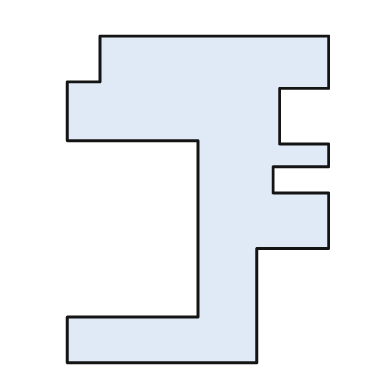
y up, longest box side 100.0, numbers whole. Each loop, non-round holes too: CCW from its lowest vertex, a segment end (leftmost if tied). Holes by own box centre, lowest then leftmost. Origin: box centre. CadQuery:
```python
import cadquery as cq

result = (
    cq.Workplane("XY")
    .moveTo(-40.0, -50.0)
    .lineTo(18.0, -50.0)
    .lineTo(18.0, -15.0)
    .lineTo(40.0, -15.0)
    .lineTo(40.0, 2.0)
    .lineTo(23.0, 2.0)
    .lineTo(23.0, 10.0)
    .lineTo(40.0, 10.0)
    .lineTo(40.0, 17.0)
    .lineTo(25.0, 17.0)
    .lineTo(25.0, 34.0)
    .lineTo(40.0, 34.0)
    .lineTo(40.0, 50.0)
    .lineTo(-30.0, 50.0)
    .lineTo(-30.0, 36.0)
    .lineTo(-40.0, 36.0)
    .lineTo(-40.0, 18.0)
    .lineTo(0.0, 18.0)
    .lineTo(0.0, -36.0)
    .lineTo(-40.0, -36.0)
    .close()
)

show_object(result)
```